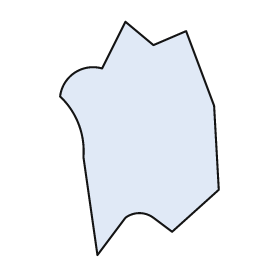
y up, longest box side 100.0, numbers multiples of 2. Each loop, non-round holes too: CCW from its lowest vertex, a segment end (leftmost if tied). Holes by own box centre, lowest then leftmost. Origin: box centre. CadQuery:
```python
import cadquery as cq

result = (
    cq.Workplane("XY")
    .moveTo(-18.0, -50.0)
    .lineTo(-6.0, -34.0)
    .threePointArc((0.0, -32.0), (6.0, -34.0))
    .lineTo(14.0, -40.0)
    .lineTo(34.0, -22.0)
    .lineTo(32.0, 14.0)
    .lineTo(20.0, 46.0)
    .lineTo(6.0, 40.0)
    .lineTo(-6.0, 50.0)
    .lineTo(-16.0, 30.0)
    .threePointArc((-28.0, 28.0), (-34.0, 18.0))
    .threePointArc((-26.0, 6.0), (-24.0, -8.0))
    .close()
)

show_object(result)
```